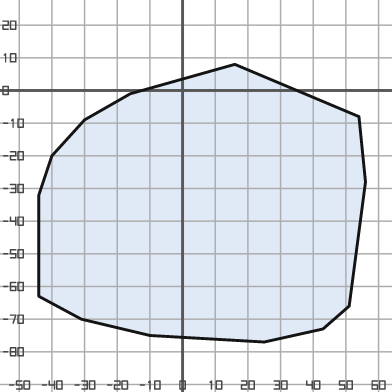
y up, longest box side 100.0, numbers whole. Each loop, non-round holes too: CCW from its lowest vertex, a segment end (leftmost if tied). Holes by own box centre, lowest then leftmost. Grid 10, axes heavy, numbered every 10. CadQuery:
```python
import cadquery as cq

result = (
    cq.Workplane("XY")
    .moveTo(25.0, -77.0)
    .lineTo(43.0, -73.0)
    .lineTo(51.0, -66.0)
    .lineTo(56.0, -28.0)
    .lineTo(54.0, -8.0)
    .lineTo(16.0, 8.0)
    .lineTo(-16.0, -1.0)
    .lineTo(-30.0, -9.0)
    .lineTo(-40.0, -20.0)
    .lineTo(-44.0, -32.0)
    .lineTo(-44.0, -63.0)
    .lineTo(-31.0, -70.0)
    .lineTo(-10.0, -75.0)
    .close()
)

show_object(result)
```